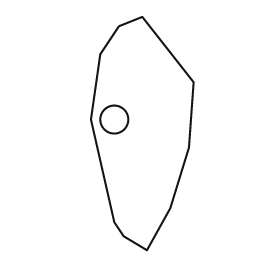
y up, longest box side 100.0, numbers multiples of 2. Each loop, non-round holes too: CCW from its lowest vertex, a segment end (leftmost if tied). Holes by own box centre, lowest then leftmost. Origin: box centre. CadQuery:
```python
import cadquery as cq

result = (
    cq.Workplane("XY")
    .moveTo(2.0, -50.0)
    .lineTo(12.0, -32.0)
    .lineTo(20.0, -6.0)
    .lineTo(22.0, 22.0)
    .lineTo(0.0, 50.0)
    .lineTo(-10.0, 46.0)
    .lineTo(-18.0, 34.0)
    .lineTo(-22.0, 6.0)
    .lineTo(-12.0, -38.0)
    .lineTo(-8.0, -44.0)
    .close()
    .moveTo(-12.0, 6.0)
    .circle(6.0)
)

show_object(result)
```